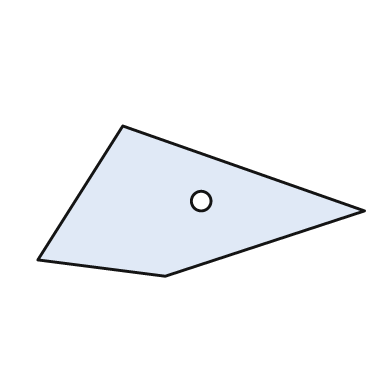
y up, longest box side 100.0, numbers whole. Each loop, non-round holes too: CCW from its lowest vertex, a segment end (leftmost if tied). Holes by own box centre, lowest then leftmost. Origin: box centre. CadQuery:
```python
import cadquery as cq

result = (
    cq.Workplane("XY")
    .moveTo(-11.0, -23.0)
    .lineTo(50.0, -3.0)
    .lineTo(-24.0, 23.0)
    .lineTo(-50.0, -18.0)
    .close()
    .moveTo(0.0, 0.0)
    .circle(3.0)
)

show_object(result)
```